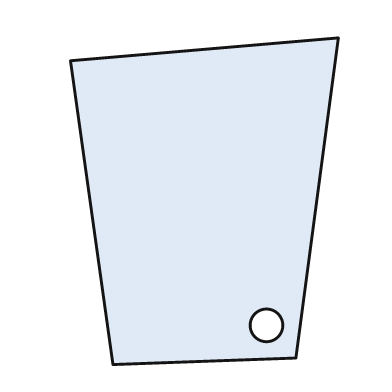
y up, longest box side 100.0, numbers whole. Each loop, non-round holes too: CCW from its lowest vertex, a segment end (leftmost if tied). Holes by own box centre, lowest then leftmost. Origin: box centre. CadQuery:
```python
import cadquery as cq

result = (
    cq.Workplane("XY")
    .moveTo(-28.0, -50.0)
    .lineTo(28.0, -48.0)
    .lineTo(41.0, 50.0)
    .lineTo(-41.0, 43.0)
    .close()
    .moveTo(19.0, -38.0)
    .circle(5.0)
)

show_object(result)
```